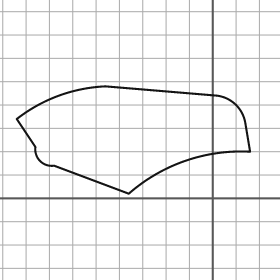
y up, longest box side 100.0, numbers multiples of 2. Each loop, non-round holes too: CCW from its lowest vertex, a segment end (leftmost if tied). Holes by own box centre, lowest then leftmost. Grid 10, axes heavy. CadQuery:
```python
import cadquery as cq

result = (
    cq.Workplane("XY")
    .moveTo(-36.0, 2.0)
    .threePointArc((-12.0, 16.0), (16.0, 20.0))
    .lineTo(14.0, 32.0)
    .threePointArc((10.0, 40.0), (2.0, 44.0))
    .lineTo(-46.0, 48.0)
    .threePointArc((-66.0, 44.0), (-84.0, 34.0))
    .lineTo(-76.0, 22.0)
    .threePointArc((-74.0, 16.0), (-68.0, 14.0))
    .close()
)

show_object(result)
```